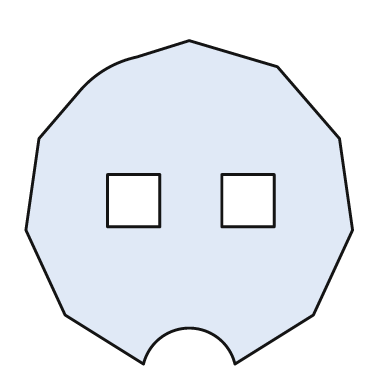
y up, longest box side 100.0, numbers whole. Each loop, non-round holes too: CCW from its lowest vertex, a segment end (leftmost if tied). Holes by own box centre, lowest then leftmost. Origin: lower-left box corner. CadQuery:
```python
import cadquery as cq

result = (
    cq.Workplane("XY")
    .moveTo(36.0, 0.0)
    .threePointArc((50.0, 11.0), (64.0, 0.0))
    .lineTo(88.0, 15.0)
    .lineTo(100.0, 41.0)
    .lineTo(96.0, 69.0)
    .lineTo(77.0, 91.0)
    .lineTo(50.0, 99.0)
    .lineTo(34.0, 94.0)
    .threePointArc((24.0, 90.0), (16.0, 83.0))
    .lineTo(4.0, 69.0)
    .lineTo(0.0, 41.0)
    .lineTo(12.0, 15.0)
    .close()
    .moveTo(25.0, 42.0)
    .lineTo(41.0, 42.0)
    .lineTo(41.0, 58.0)
    .lineTo(25.0, 58.0)
    .close()
    .moveTo(60.0, 42.0)
    .lineTo(76.0, 42.0)
    .lineTo(76.0, 58.0)
    .lineTo(60.0, 58.0)
    .close()
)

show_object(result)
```